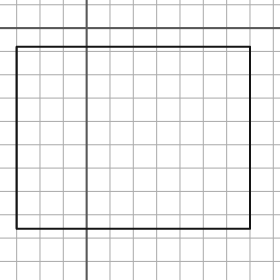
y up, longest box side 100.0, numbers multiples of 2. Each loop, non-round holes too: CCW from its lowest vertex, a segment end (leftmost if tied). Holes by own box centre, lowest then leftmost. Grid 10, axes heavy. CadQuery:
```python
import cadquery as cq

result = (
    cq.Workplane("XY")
    .moveTo(-30.0, -86.0)
    .lineTo(70.0, -86.0)
    .lineTo(70.0, -8.0)
    .lineTo(-30.0, -8.0)
    .close()
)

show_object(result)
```